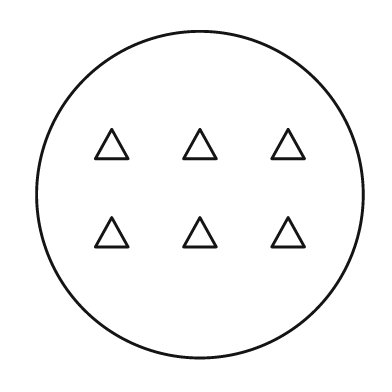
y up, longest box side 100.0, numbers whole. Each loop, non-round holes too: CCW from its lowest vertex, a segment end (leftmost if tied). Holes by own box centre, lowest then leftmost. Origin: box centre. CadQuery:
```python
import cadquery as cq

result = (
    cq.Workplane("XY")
    .moveTo(0.0, 0.0)
    .circle(50.0)
    .moveTo(-32.0, -16.0)
    .lineTo(-22.0, -16.0)
    .lineTo(-27.0, -7.0)
    .close()
    .moveTo(-5.0, -16.0)
    .lineTo(5.0, -16.0)
    .lineTo(0.0, -7.0)
    .close()
    .moveTo(22.0, -16.0)
    .lineTo(32.0, -16.0)
    .lineTo(27.0, -7.0)
    .close()
    .moveTo(-32.0, 11.0)
    .lineTo(-22.0, 11.0)
    .lineTo(-27.0, 20.0)
    .close()
    .moveTo(-5.0, 11.0)
    .lineTo(5.0, 11.0)
    .lineTo(0.0, 20.0)
    .close()
    .moveTo(22.0, 11.0)
    .lineTo(32.0, 11.0)
    .lineTo(27.0, 20.0)
    .close()
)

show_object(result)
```